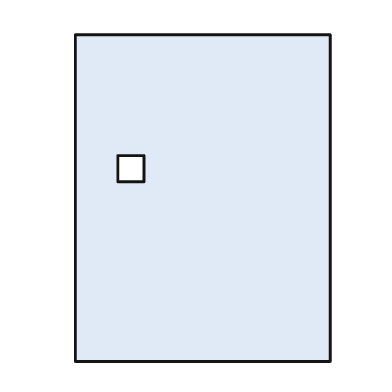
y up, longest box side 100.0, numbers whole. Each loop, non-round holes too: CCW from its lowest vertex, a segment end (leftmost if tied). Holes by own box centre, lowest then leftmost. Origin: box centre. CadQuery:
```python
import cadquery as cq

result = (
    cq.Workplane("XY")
    .moveTo(-39.0, -50.0)
    .lineTo(39.0, -50.0)
    .lineTo(39.0, 50.0)
    .lineTo(-39.0, 50.0)
    .close()
    .moveTo(-26.0, 5.0)
    .lineTo(-18.0, 5.0)
    .lineTo(-18.0, 13.0)
    .lineTo(-26.0, 13.0)
    .close()
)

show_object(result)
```